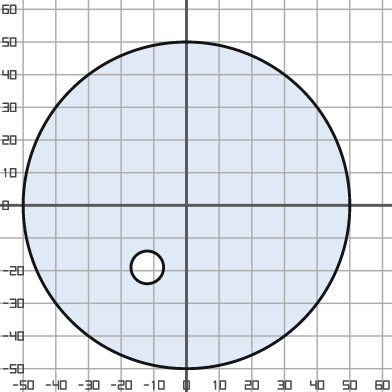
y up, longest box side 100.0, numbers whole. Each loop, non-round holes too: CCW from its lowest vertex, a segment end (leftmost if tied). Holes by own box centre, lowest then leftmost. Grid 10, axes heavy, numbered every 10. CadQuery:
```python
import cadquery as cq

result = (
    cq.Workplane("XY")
    .moveTo(0.0, 0.0)
    .circle(50.0)
    .moveTo(-12.0, -19.0)
    .circle(5.0)
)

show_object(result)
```